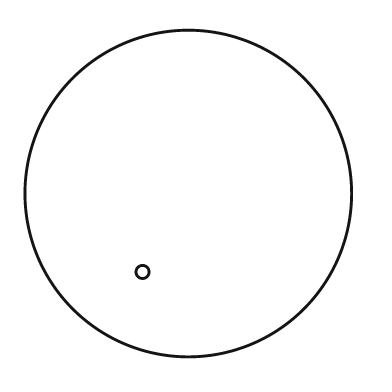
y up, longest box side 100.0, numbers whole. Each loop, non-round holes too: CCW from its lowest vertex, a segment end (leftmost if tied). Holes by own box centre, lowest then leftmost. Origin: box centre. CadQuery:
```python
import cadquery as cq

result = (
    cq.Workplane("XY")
    .moveTo(0.0, 0.0)
    .circle(50.0)
    .moveTo(-14.0, -24.0)
    .circle(2.0)
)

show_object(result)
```